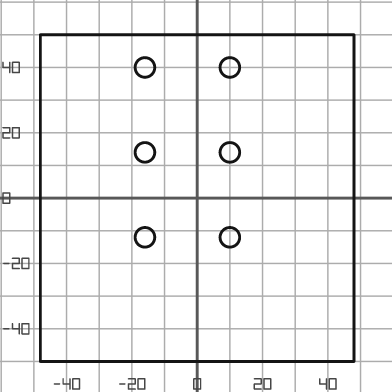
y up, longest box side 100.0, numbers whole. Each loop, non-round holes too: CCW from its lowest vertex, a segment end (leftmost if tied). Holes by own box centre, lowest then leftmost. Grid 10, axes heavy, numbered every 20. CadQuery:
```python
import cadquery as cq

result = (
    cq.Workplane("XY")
    .moveTo(-48.0, -50.0)
    .lineTo(48.0, -50.0)
    .lineTo(48.0, 50.0)
    .lineTo(-48.0, 50.0)
    .close()
    .moveTo(-16.0, -12.0)
    .circle(3.0)
    .moveTo(10.0, -12.0)
    .circle(3.0)
    .moveTo(-16.0, 14.0)
    .circle(3.0)
    .moveTo(10.0, 14.0)
    .circle(3.0)
    .moveTo(-16.0, 40.0)
    .circle(3.0)
    .moveTo(10.0, 40.0)
    .circle(3.0)
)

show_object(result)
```